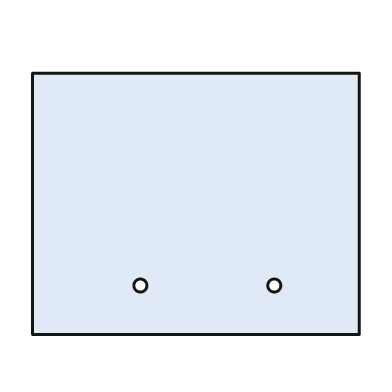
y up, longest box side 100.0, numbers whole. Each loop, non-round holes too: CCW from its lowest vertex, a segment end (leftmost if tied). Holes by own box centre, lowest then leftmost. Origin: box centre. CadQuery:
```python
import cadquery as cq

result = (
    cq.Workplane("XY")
    .moveTo(-50.0, -40.0)
    .lineTo(50.0, -40.0)
    .lineTo(50.0, 40.0)
    .lineTo(-50.0, 40.0)
    .close()
    .moveTo(-17.0, -25.0)
    .circle(2.0)
    .moveTo(24.0, -25.0)
    .circle(2.0)
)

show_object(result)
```